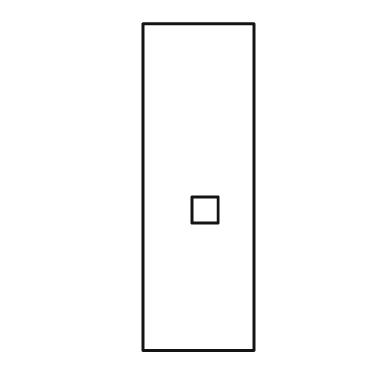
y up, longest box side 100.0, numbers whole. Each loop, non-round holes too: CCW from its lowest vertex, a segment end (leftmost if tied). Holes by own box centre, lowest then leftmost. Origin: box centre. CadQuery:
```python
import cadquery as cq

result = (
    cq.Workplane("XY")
    .moveTo(-17.0, -50.0)
    .lineTo(17.0, -50.0)
    .lineTo(17.0, 50.0)
    .lineTo(-17.0, 50.0)
    .close()
    .moveTo(-2.0, -11.0)
    .lineTo(6.0, -11.0)
    .lineTo(6.0, -3.0)
    .lineTo(-2.0, -3.0)
    .close()
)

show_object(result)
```